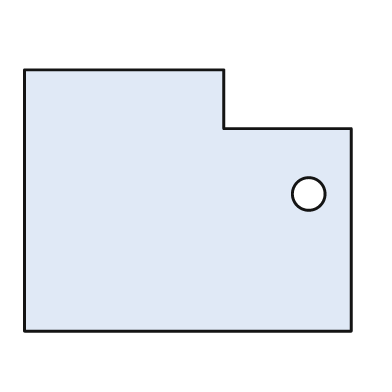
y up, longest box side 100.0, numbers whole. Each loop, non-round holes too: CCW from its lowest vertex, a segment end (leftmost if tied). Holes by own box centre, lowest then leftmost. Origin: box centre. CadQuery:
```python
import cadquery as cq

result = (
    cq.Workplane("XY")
    .moveTo(-50.0, -40.0)
    .lineTo(50.0, -40.0)
    .lineTo(50.0, 22.0)
    .lineTo(11.0, 22.0)
    .lineTo(11.0, 40.0)
    .lineTo(-50.0, 40.0)
    .close()
    .moveTo(37.0, 2.0)
    .circle(5.0)
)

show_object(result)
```